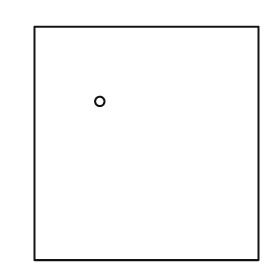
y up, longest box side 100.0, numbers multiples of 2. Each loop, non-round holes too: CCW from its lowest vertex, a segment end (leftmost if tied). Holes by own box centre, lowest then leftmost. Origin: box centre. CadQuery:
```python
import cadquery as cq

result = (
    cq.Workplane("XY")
    .moveTo(-48.0, -50.0)
    .lineTo(48.0, -50.0)
    .lineTo(48.0, 50.0)
    .lineTo(-48.0, 50.0)
    .close()
    .moveTo(-20.0, 18.0)
    .circle(2.0)
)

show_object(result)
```